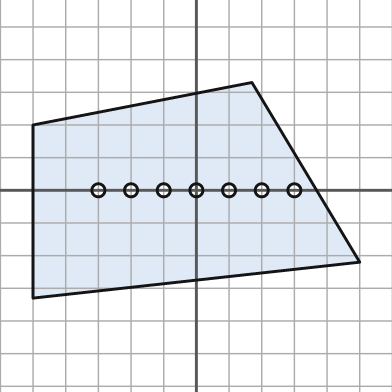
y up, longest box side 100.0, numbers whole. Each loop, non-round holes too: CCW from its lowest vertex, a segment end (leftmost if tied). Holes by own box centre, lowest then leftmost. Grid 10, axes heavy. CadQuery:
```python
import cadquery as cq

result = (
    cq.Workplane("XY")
    .moveTo(-50.0, -33.0)
    .lineTo(50.0, -22.0)
    .lineTo(17.0, 33.0)
    .lineTo(-50.0, 20.0)
    .close()
    .moveTo(-30.0, 0.0)
    .circle(2.0)
    .moveTo(-20.0, 0.0)
    .circle(2.0)
    .moveTo(-10.0, 0.0)
    .circle(2.0)
    .moveTo(0.0, 0.0)
    .circle(2.0)
    .moveTo(10.0, 0.0)
    .circle(2.0)
    .moveTo(20.0, 0.0)
    .circle(2.0)
    .moveTo(30.0, 0.0)
    .circle(2.0)
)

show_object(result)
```